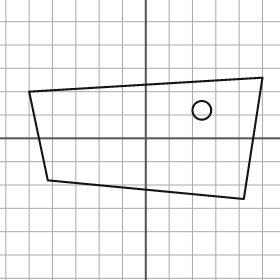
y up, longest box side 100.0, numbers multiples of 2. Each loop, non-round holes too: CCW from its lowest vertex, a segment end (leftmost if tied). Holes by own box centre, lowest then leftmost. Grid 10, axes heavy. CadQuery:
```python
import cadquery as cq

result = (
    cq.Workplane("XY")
    .moveTo(42.0, -26.0)
    .lineTo(50.0, 26.0)
    .lineTo(-50.0, 20.0)
    .lineTo(-42.0, -18.0)
    .close()
    .moveTo(24.0, 12.0)
    .circle(4.0)
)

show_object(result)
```